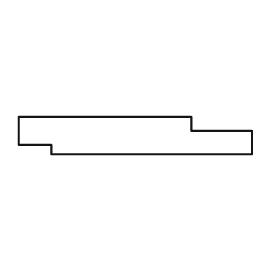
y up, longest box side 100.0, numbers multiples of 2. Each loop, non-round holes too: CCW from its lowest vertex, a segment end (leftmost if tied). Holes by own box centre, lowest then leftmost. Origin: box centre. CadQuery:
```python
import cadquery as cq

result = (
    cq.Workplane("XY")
    .moveTo(-36.0, -8.0)
    .lineTo(50.0, -8.0)
    .lineTo(50.0, 2.0)
    .lineTo(24.0, 2.0)
    .lineTo(24.0, 8.0)
    .lineTo(-50.0, 8.0)
    .lineTo(-50.0, -4.0)
    .lineTo(-36.0, -4.0)
    .close()
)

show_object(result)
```